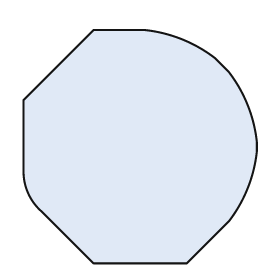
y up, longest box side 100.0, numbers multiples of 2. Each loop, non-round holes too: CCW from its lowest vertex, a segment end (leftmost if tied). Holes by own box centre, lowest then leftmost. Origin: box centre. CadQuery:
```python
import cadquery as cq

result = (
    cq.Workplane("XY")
    .moveTo(-20.0, -50.0)
    .lineTo(20.0, -50.0)
    .lineTo(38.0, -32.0)
    .threePointArc((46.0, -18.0), (50.0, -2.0))
    .lineTo(50.0, 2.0)
    .threePointArc((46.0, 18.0), (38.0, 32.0))
    .lineTo(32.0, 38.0)
    .threePointArc((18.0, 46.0), (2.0, 50.0))
    .lineTo(-20.0, 50.0)
    .lineTo(-50.0, 20.0)
    .lineTo(-50.0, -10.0)
    .threePointArc((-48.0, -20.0), (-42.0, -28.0))
    .close()
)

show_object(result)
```